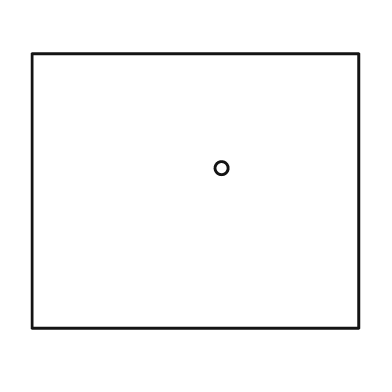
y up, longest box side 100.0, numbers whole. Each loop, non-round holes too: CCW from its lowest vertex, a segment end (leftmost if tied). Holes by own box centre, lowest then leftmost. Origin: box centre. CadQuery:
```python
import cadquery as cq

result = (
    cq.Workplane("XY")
    .moveTo(-50.0, -42.0)
    .lineTo(50.0, -42.0)
    .lineTo(50.0, 42.0)
    .lineTo(-50.0, 42.0)
    .close()
    .moveTo(8.0, 7.0)
    .circle(2.0)
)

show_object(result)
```